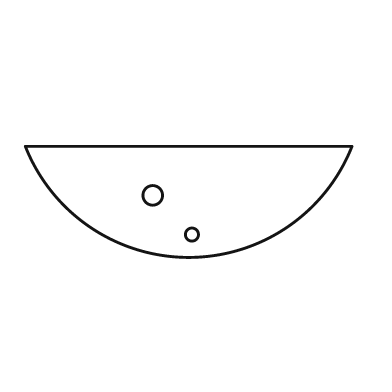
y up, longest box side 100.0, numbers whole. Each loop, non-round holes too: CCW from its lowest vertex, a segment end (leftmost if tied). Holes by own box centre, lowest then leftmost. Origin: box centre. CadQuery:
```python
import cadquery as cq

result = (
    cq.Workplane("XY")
    .moveTo(-50.0, 17.0)
    .threePointArc((0.0, -17.0), (50.0, 17.0))
    .close()
    .moveTo(1.0, -10.0)
    .circle(2.0)
    .moveTo(-11.0, 2.0)
    .circle(3.0)
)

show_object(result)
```